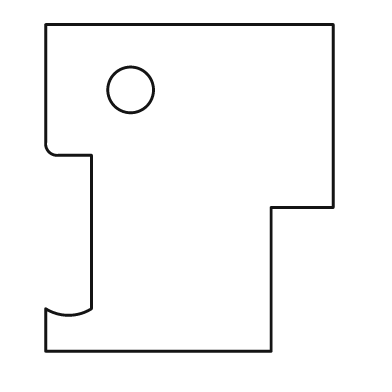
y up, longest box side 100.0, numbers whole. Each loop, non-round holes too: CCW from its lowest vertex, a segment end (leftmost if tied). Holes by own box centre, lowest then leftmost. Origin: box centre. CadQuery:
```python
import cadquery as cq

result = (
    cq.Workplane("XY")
    .moveTo(-44.0, -50.0)
    .lineTo(25.0, -50.0)
    .lineTo(25.0, -6.0)
    .lineTo(44.0, -6.0)
    .lineTo(44.0, 50.0)
    .lineTo(-44.0, 50.0)
    .lineTo(-44.0, 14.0)
    .threePointArc((-43.0, 11.0), (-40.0, 10.0))
    .lineTo(-30.0, 10.0)
    .lineTo(-30.0, -37.0)
    .threePointArc((-37.0, -39.0), (-44.0, -37.0))
    .close()
    .moveTo(-18.0, 30.0)
    .circle(7.0)
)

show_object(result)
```